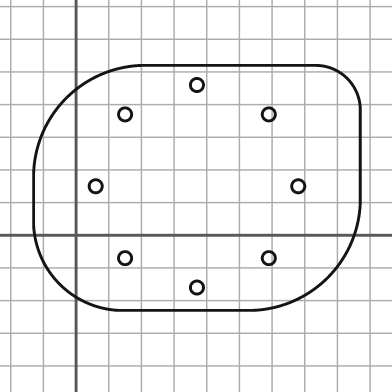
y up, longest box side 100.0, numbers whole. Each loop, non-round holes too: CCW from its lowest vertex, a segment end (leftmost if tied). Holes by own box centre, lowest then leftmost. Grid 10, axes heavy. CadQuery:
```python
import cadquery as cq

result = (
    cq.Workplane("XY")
    .moveTo(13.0, -23.0)
    .lineTo(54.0, -23.0)
    .threePointArc((77.0, -13.0), (87.0, 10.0))
    .lineTo(87.0, 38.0)
    .threePointArc((83.0, 48.0), (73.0, 52.0))
    .lineTo(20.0, 52.0)
    .threePointArc((-3.0, 42.0), (-13.0, 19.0))
    .lineTo(-13.0, 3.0)
    .threePointArc((-5.0, -15.0), (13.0, -23.0))
    .close()
    .moveTo(37.0, -16.0)
    .circle(2.0)
    .moveTo(15.0, -7.0)
    .circle(2.0)
    .moveTo(59.0, -7.0)
    .circle(2.0)
    .moveTo(6.0, 15.0)
    .circle(2.0)
    .moveTo(68.0, 15.0)
    .circle(2.0)
    .moveTo(15.0, 37.0)
    .circle(2.0)
    .moveTo(59.0, 37.0)
    .circle(2.0)
    .moveTo(37.0, 46.0)
    .circle(2.0)
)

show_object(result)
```